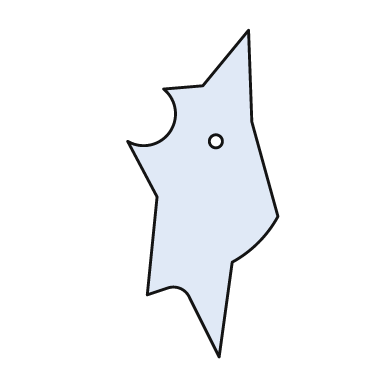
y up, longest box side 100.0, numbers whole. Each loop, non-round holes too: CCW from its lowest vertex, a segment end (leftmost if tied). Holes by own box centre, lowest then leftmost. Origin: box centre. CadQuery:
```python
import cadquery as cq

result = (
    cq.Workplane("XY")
    .moveTo(5.0, -50.0)
    .lineTo(9.0, -21.0)
    .threePointArc((17.0, -15.0), (23.0, -7.0))
    .lineTo(15.0, 22.0)
    .lineTo(14.0, 50.0)
    .lineTo(0.0, 33.0)
    .lineTo(-12.0, 32.0)
    .threePointArc((-10.0, 19.0), (-23.0, 16.0))
    .lineTo(-14.0, -1.0)
    .lineTo(-17.0, -31.0)
    .lineTo(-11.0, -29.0)
    .threePointArc((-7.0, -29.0), (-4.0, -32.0))
    .close()
    .moveTo(4.0, 16.0)
    .circle(2.0)
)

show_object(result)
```